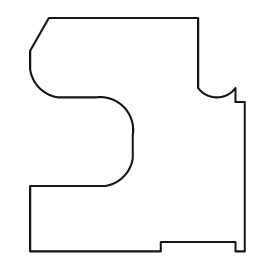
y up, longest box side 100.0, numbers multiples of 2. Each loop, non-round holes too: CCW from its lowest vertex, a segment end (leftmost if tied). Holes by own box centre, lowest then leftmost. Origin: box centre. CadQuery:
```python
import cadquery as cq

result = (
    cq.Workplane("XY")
    .moveTo(-46.0, -50.0)
    .lineTo(10.0, -50.0)
    .lineTo(10.0, -46.0)
    .lineTo(42.0, -46.0)
    .lineTo(42.0, -50.0)
    .lineTo(46.0, -50.0)
    .lineTo(46.0, 14.0)
    .lineTo(42.0, 14.0)
    .lineTo(42.0, 20.0)
    .threePointArc((34.0, 16.0), (26.0, 20.0))
    .lineTo(26.0, 50.0)
    .lineTo(-38.0, 50.0)
    .lineTo(-46.0, 36.0)
    .lineTo(-46.0, 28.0)
    .threePointArc((-42.0, 20.0), (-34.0, 16.0))
    .lineTo(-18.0, 16.0)
    .threePointArc((-6.0, 12.0), (-2.0, 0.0))
    .lineTo(-2.0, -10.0)
    .threePointArc((-6.0, -18.0), (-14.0, -22.0))
    .lineTo(-46.0, -22.0)
    .close()
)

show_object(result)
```